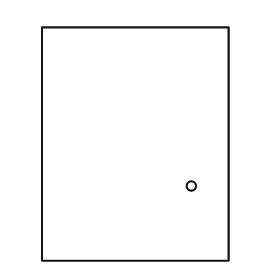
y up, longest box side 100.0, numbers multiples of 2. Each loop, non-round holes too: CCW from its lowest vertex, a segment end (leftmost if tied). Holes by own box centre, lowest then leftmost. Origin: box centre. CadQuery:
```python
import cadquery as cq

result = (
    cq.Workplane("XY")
    .moveTo(-40.0, -50.0)
    .lineTo(40.0, -50.0)
    .lineTo(40.0, 50.0)
    .lineTo(-40.0, 50.0)
    .close()
    .moveTo(24.0, -18.0)
    .circle(2.0)
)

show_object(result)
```